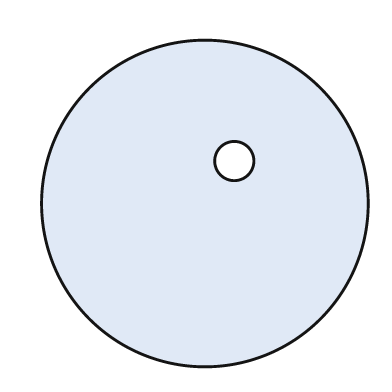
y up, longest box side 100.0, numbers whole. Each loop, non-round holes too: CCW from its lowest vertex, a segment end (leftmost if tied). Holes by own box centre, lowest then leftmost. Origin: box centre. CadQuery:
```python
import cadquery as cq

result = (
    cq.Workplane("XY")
    .moveTo(0.0, 0.0)
    .circle(50.0)
    .moveTo(9.0, 13.0)
    .circle(6.0)
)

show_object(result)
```